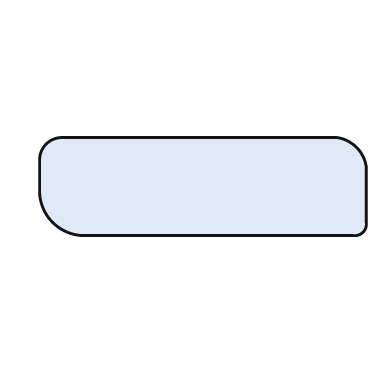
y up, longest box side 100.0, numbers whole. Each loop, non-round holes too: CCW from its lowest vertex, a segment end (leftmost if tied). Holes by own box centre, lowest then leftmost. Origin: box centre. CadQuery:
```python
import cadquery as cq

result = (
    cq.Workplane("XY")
    .moveTo(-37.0, -15.0)
    .lineTo(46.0, -15.0)
    .threePointArc((49.0, -14.0), (50.0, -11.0))
    .lineTo(50.0, 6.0)
    .threePointArc((47.0, 12.0), (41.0, 15.0))
    .lineTo(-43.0, 15.0)
    .threePointArc((-48.0, 13.0), (-50.0, 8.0))
    .lineTo(-50.0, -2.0)
    .threePointArc((-46.0, -11.0), (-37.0, -15.0))
    .close()
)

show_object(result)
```